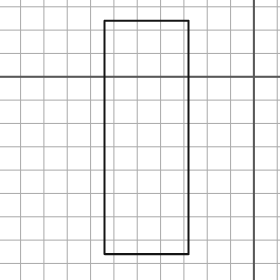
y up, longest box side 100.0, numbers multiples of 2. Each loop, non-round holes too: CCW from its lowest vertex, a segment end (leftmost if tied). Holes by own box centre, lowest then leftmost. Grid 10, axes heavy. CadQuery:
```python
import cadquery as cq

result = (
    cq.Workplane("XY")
    .moveTo(-64.0, -76.0)
    .lineTo(-28.0, -76.0)
    .lineTo(-28.0, 24.0)
    .lineTo(-64.0, 24.0)
    .close()
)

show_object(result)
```